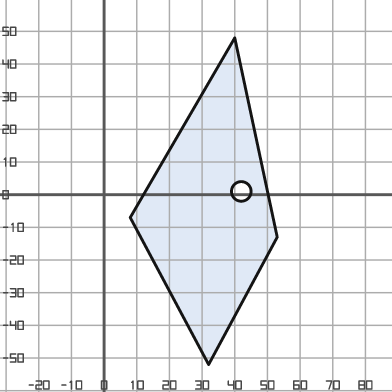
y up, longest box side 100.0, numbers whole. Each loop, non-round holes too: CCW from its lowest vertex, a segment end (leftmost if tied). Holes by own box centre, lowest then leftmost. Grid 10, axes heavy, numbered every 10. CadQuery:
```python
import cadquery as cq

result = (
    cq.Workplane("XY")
    .moveTo(32.0, -52.0)
    .lineTo(53.0, -13.0)
    .lineTo(40.0, 48.0)
    .lineTo(8.0, -7.0)
    .close()
    .moveTo(42.0, 1.0)
    .circle(3.0)
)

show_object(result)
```